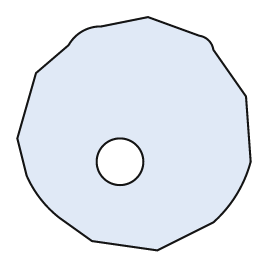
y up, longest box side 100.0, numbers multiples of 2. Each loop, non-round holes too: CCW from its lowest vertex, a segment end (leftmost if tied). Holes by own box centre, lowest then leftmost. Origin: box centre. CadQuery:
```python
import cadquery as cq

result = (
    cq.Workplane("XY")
    .moveTo(10.0, -50.0)
    .lineTo(34.0, -38.0)
    .threePointArc((44.0, -26.0), (50.0, -12.0))
    .lineTo(48.0, 16.0)
    .lineTo(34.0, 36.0)
    .threePointArc((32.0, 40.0), (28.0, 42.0))
    .lineTo(6.0, 50.0)
    .lineTo(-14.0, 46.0)
    .threePointArc((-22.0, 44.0), (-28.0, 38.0))
    .lineTo(-42.0, 26.0)
    .lineTo(-50.0, -2.0)
    .lineTo(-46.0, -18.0)
    .threePointArc((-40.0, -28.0), (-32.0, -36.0))
    .lineTo(-18.0, -46.0)
    .close()
    .moveTo(-6.0, -12.0)
    .circle(10.0)
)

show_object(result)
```